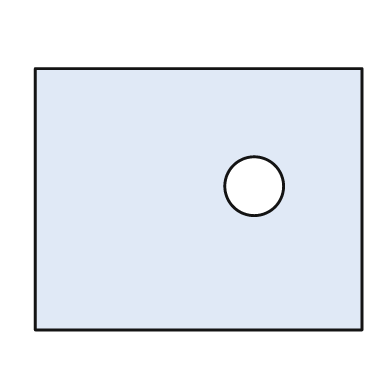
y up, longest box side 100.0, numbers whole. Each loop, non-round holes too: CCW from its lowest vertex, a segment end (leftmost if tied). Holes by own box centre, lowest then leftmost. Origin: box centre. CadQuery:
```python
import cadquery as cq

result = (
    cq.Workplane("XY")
    .moveTo(-50.0, -40.0)
    .lineTo(50.0, -40.0)
    .lineTo(50.0, 40.0)
    .lineTo(-50.0, 40.0)
    .close()
    .moveTo(17.0, 4.0)
    .circle(9.0)
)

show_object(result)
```